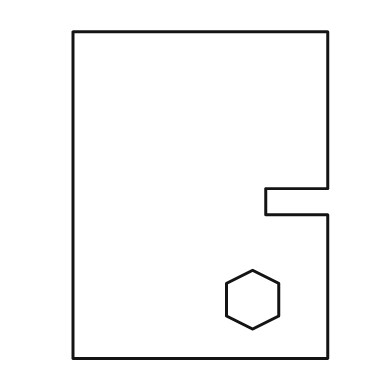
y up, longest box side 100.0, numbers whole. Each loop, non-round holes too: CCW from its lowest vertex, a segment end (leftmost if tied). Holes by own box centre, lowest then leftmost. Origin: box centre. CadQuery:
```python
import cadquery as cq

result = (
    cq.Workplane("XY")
    .moveTo(-39.0, -50.0)
    .lineTo(39.0, -50.0)
    .lineTo(39.0, -6.0)
    .lineTo(20.0, -6.0)
    .lineTo(20.0, 2.0)
    .lineTo(39.0, 2.0)
    .lineTo(39.0, 50.0)
    .lineTo(-39.0, 50.0)
    .close()
    .moveTo(16.0, -41.0)
    .lineTo(24.0, -37.0)
    .lineTo(24.0, -27.0)
    .lineTo(16.0, -23.0)
    .lineTo(8.0, -27.0)
    .lineTo(8.0, -37.0)
    .close()
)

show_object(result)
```